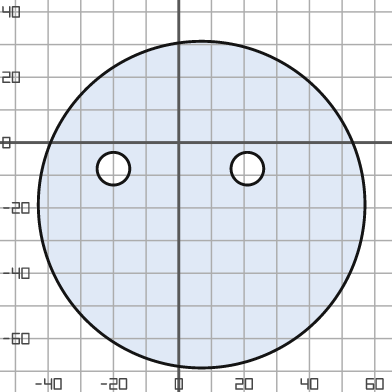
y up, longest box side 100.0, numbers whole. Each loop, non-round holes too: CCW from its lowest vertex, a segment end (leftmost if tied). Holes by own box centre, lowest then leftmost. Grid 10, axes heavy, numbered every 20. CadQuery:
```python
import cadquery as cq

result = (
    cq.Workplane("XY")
    .moveTo(7.0, -19.0)
    .circle(50.0)
    .moveTo(-20.0, -8.0)
    .circle(5.0)
    .moveTo(21.0, -8.0)
    .circle(5.0)
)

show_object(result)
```